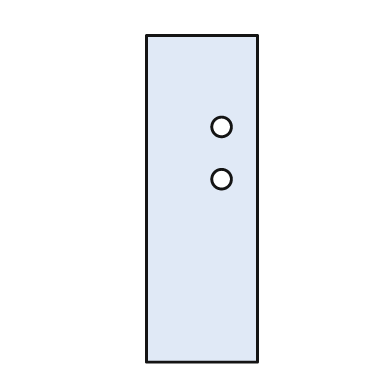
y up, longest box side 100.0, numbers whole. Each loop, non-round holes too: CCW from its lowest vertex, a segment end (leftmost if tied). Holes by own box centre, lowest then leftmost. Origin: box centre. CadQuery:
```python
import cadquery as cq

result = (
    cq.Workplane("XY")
    .moveTo(-17.0, -50.0)
    .lineTo(17.0, -50.0)
    .lineTo(17.0, 50.0)
    .lineTo(-17.0, 50.0)
    .close()
    .moveTo(6.0, 6.0)
    .circle(3.0)
    .moveTo(6.0, 22.0)
    .circle(3.0)
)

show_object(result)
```